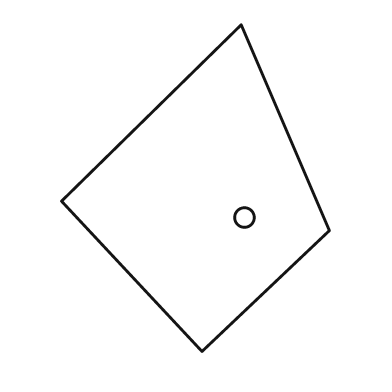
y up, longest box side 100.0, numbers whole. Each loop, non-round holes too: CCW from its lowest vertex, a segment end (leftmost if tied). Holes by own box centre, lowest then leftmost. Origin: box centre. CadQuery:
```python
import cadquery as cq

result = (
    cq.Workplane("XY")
    .moveTo(2.0, -50.0)
    .lineTo(41.0, -13.0)
    .lineTo(14.0, 50.0)
    .lineTo(-41.0, -4.0)
    .close()
    .moveTo(15.0, -9.0)
    .circle(3.0)
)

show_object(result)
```